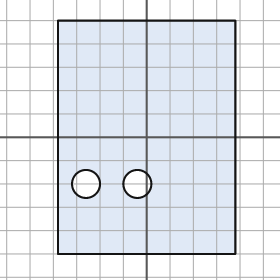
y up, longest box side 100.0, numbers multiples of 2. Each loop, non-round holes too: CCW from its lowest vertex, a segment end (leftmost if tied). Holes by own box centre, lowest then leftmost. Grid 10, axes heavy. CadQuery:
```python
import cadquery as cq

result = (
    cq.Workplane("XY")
    .moveTo(-38.0, -50.0)
    .lineTo(38.0, -50.0)
    .lineTo(38.0, 50.0)
    .lineTo(-38.0, 50.0)
    .close()
    .moveTo(-26.0, -20.0)
    .circle(6.0)
    .moveTo(-4.0, -20.0)
    .circle(6.0)
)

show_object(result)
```